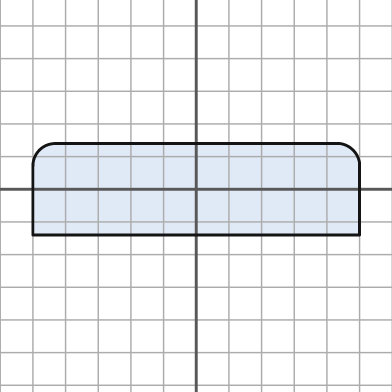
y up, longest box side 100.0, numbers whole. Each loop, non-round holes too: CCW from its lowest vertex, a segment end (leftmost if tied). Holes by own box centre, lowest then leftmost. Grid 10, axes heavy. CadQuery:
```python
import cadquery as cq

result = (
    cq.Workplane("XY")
    .moveTo(-50.0, -14.0)
    .lineTo(50.0, -14.0)
    .lineTo(50.0, 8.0)
    .threePointArc((48.0, 12.0), (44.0, 14.0))
    .lineTo(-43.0, 14.0)
    .threePointArc((-48.0, 12.0), (-50.0, 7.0))
    .close()
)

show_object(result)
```